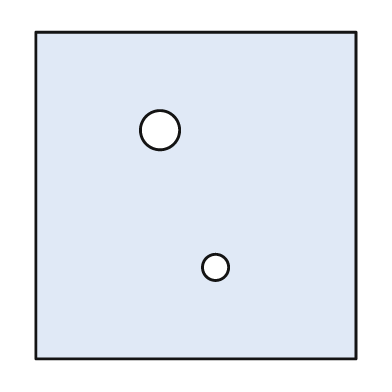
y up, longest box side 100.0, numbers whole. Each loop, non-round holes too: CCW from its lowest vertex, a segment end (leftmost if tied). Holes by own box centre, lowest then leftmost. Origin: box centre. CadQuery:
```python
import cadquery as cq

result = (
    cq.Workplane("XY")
    .moveTo(-49.0, -50.0)
    .lineTo(49.0, -50.0)
    .lineTo(49.0, 50.0)
    .lineTo(-49.0, 50.0)
    .close()
    .moveTo(6.0, -22.0)
    .circle(4.0)
    .moveTo(-11.0, 20.0)
    .circle(6.0)
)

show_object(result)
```